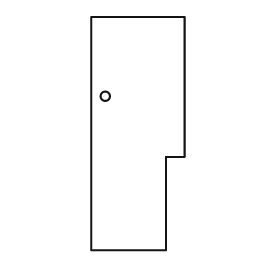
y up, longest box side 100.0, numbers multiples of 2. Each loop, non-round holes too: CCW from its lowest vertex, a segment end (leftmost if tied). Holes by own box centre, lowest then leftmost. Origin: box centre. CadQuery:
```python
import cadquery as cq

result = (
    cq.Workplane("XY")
    .moveTo(-20.0, -50.0)
    .lineTo(12.0, -50.0)
    .lineTo(12.0, -10.0)
    .lineTo(20.0, -10.0)
    .lineTo(20.0, 50.0)
    .lineTo(-20.0, 50.0)
    .close()
    .moveTo(-14.0, 16.0)
    .circle(2.0)
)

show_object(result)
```